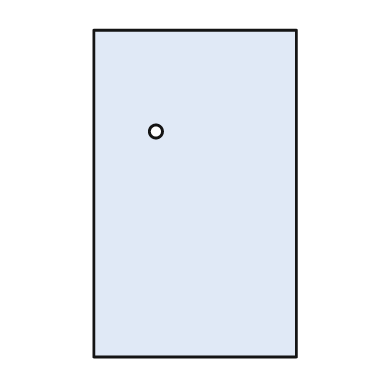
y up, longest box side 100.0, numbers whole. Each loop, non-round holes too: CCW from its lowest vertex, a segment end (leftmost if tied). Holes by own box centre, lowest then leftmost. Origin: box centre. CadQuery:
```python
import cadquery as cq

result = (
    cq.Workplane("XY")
    .moveTo(-31.0, -50.0)
    .lineTo(31.0, -50.0)
    .lineTo(31.0, 50.0)
    .lineTo(-31.0, 50.0)
    .close()
    .moveTo(-12.0, 19.0)
    .circle(2.0)
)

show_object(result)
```